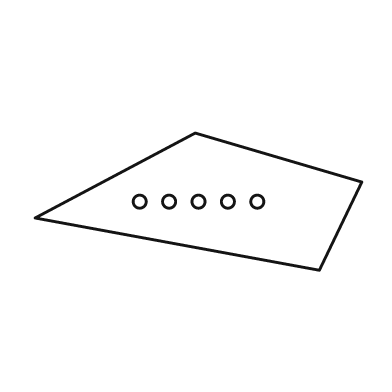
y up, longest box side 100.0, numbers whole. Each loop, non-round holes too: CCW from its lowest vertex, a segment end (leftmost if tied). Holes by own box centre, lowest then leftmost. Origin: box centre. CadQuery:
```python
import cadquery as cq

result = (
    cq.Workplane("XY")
    .moveTo(37.0, -21.0)
    .lineTo(50.0, 6.0)
    .lineTo(-1.0, 21.0)
    .lineTo(-50.0, -5.0)
    .close()
    .moveTo(-18.0, 0.0)
    .circle(2.0)
    .moveTo(-9.0, 0.0)
    .circle(2.0)
    .moveTo(0.0, 0.0)
    .circle(2.0)
    .moveTo(9.0, 0.0)
    .circle(2.0)
    .moveTo(18.0, 0.0)
    .circle(2.0)
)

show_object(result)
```